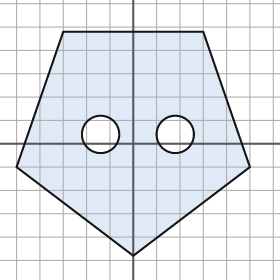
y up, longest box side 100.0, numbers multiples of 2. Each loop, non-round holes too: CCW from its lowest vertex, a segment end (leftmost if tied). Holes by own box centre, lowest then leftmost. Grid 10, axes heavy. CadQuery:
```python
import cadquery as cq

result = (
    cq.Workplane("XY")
    .moveTo(0.0, -48.0)
    .lineTo(50.0, -10.0)
    .lineTo(30.0, 48.0)
    .lineTo(-30.0, 48.0)
    .lineTo(-50.0, -10.0)
    .close()
    .moveTo(-14.0, 4.0)
    .circle(8.0)
    .moveTo(18.0, 4.0)
    .circle(8.0)
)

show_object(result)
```